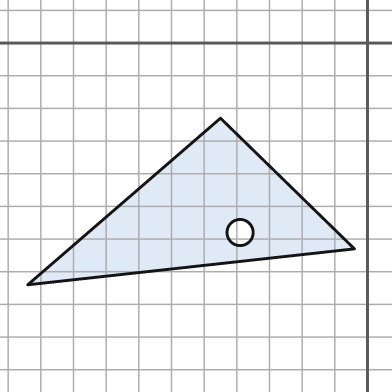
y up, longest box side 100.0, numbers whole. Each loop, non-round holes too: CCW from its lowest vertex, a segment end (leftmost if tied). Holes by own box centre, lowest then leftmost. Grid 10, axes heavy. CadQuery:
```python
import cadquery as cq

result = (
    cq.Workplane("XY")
    .moveTo(-104.0, -74.0)
    .lineTo(-4.0, -63.0)
    .lineTo(-45.0, -23.0)
    .close()
    .moveTo(-39.0, -58.0)
    .circle(4.0)
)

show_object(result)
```